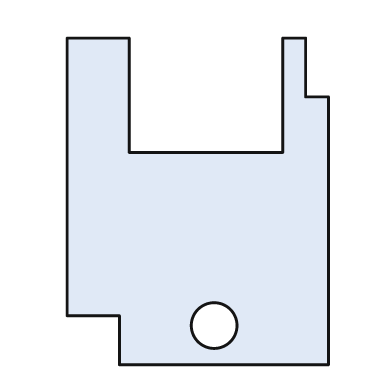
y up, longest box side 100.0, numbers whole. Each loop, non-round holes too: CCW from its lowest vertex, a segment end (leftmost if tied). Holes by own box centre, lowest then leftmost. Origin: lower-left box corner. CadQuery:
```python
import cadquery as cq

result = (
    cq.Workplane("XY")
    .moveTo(16.0, 0.0)
    .lineTo(80.0, 0.0)
    .lineTo(80.0, 82.0)
    .lineTo(73.0, 82.0)
    .lineTo(73.0, 100.0)
    .lineTo(66.0, 100.0)
    .lineTo(66.0, 65.0)
    .lineTo(19.0, 65.0)
    .lineTo(19.0, 100.0)
    .lineTo(0.0, 100.0)
    .lineTo(0.0, 15.0)
    .lineTo(16.0, 15.0)
    .close()
    .moveTo(45.0, 12.0)
    .circle(7.0)
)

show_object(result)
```